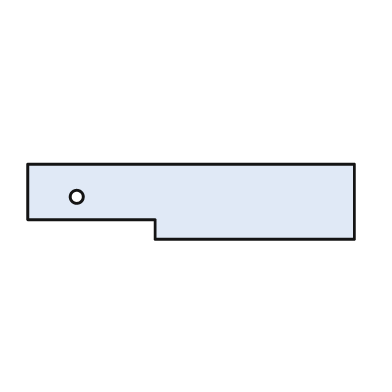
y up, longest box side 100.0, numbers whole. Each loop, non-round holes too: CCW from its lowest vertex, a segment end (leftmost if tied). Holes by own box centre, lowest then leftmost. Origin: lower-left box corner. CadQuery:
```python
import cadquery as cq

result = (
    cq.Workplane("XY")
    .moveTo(39.0, 0.0)
    .lineTo(100.0, 0.0)
    .lineTo(100.0, 23.0)
    .lineTo(0.0, 23.0)
    .lineTo(0.0, 6.0)
    .lineTo(39.0, 6.0)
    .close()
    .moveTo(15.0, 13.0)
    .circle(2.0)
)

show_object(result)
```